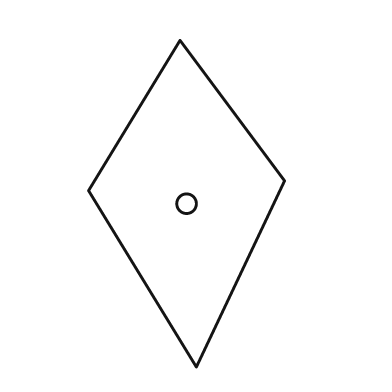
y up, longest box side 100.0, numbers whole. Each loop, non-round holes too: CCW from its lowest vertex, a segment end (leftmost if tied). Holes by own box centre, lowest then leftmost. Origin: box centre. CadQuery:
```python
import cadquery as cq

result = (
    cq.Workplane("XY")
    .moveTo(3.0, -50.0)
    .lineTo(30.0, 7.0)
    .lineTo(-2.0, 50.0)
    .lineTo(-30.0, 4.0)
    .close()
    .moveTo(0.0, 0.0)
    .circle(3.0)
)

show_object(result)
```